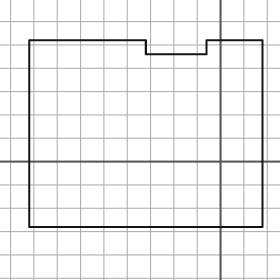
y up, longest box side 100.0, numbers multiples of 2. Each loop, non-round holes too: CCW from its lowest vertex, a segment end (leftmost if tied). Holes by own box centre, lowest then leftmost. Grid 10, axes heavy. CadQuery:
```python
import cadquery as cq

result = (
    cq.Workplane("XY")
    .moveTo(-82.0, -28.0)
    .lineTo(18.0, -28.0)
    .lineTo(18.0, 52.0)
    .lineTo(-6.0, 52.0)
    .lineTo(-6.0, 46.0)
    .lineTo(-32.0, 46.0)
    .lineTo(-32.0, 52.0)
    .lineTo(-82.0, 52.0)
    .close()
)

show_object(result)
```